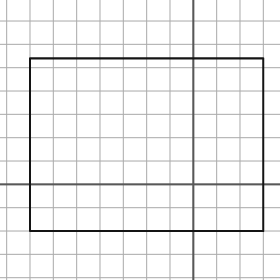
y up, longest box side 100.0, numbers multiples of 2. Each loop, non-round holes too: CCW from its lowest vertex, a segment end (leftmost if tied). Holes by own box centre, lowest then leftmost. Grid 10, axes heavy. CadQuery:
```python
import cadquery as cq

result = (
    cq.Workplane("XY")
    .moveTo(-70.0, -20.0)
    .lineTo(30.0, -20.0)
    .lineTo(30.0, 54.0)
    .lineTo(-70.0, 54.0)
    .close()
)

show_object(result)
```